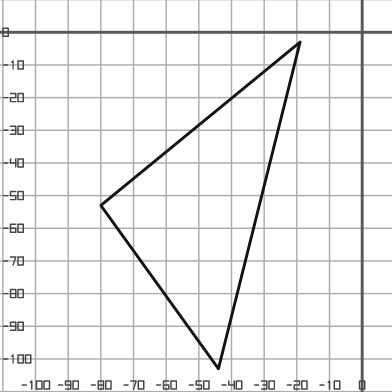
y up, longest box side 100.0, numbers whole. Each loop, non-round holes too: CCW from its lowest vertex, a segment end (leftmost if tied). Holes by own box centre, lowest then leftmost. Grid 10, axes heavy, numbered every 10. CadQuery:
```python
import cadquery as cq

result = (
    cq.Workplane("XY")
    .moveTo(-44.0, -103.0)
    .lineTo(-19.0, -3.0)
    .lineTo(-80.0, -53.0)
    .close()
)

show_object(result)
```